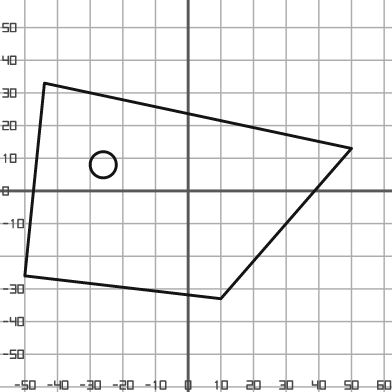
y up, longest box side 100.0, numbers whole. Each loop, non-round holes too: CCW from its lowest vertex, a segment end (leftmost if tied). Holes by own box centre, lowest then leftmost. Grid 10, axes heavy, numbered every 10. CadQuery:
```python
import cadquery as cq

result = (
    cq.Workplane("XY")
    .moveTo(10.0, -33.0)
    .lineTo(50.0, 13.0)
    .lineTo(-44.0, 33.0)
    .lineTo(-50.0, -26.0)
    .close()
    .moveTo(-26.0, 8.0)
    .circle(4.0)
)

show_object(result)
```